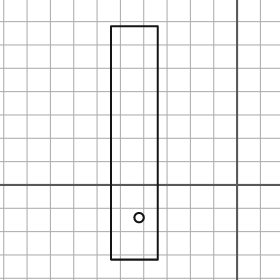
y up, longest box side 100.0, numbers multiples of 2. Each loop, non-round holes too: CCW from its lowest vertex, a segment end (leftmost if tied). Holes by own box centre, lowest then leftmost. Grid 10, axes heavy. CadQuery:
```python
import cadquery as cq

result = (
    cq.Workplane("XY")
    .moveTo(-54.0, -32.0)
    .lineTo(-34.0, -32.0)
    .lineTo(-34.0, 68.0)
    .lineTo(-54.0, 68.0)
    .close()
    .moveTo(-42.0, -14.0)
    .circle(2.0)
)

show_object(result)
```